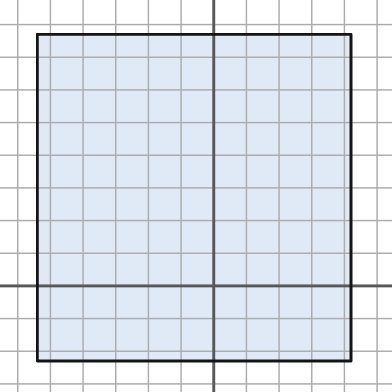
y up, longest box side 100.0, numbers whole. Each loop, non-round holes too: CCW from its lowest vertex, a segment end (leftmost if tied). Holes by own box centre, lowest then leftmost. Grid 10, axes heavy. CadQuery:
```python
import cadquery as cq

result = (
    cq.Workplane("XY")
    .moveTo(-54.0, -23.0)
    .lineTo(42.0, -23.0)
    .lineTo(42.0, 77.0)
    .lineTo(-54.0, 77.0)
    .close()
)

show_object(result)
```